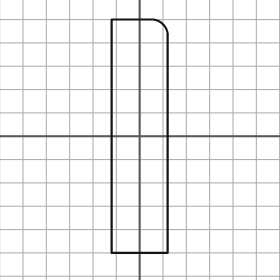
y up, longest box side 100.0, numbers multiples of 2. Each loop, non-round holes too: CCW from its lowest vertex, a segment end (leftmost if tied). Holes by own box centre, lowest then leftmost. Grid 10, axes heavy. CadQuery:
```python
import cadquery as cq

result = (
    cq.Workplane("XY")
    .moveTo(-12.0, -50.0)
    .lineTo(12.0, -50.0)
    .lineTo(12.0, 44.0)
    .threePointArc((10.0, 48.0), (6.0, 50.0))
    .lineTo(-12.0, 50.0)
    .close()
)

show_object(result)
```